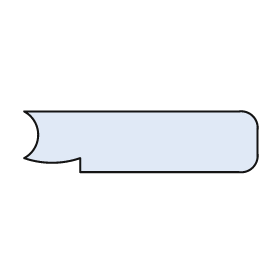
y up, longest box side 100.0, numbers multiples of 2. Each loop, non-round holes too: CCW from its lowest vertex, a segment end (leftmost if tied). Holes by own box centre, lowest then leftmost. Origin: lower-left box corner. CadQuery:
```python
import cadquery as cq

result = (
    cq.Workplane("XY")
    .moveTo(24.0, 0.0)
    .lineTo(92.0, 0.0)
    .threePointArc((98.0, 2.0), (100.0, 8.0))
    .lineTo(100.0, 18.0)
    .threePointArc((98.0, 24.0), (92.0, 26.0))
    .lineTo(0.0, 26.0)
    .threePointArc((6.0, 16.0), (0.0, 6.0))
    .threePointArc((12.0, 4.0), (24.0, 6.0))
    .close()
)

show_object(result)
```